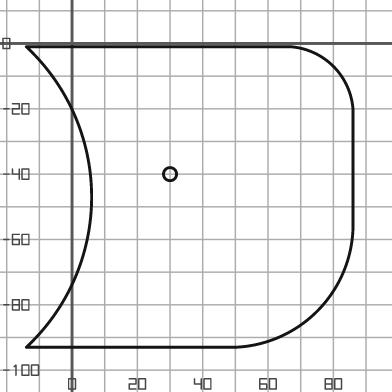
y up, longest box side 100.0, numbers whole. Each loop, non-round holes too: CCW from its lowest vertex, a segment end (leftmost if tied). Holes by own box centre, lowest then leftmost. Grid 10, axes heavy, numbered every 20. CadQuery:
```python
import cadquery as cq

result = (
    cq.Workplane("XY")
    .moveTo(-14.0, -93.0)
    .lineTo(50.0, -93.0)
    .threePointArc((75.0, -82.0), (86.0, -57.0))
    .lineTo(86.0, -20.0)
    .threePointArc((80.0, -7.0), (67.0, -1.0))
    .lineTo(-14.0, -1.0)
    .threePointArc((6.0, -47.0), (-14.0, -93.0))
    .close()
    .moveTo(30.0, -40.0)
    .circle(2.0)
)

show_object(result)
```